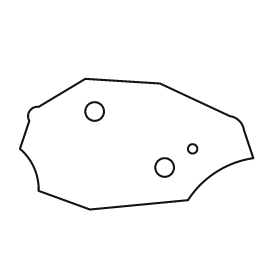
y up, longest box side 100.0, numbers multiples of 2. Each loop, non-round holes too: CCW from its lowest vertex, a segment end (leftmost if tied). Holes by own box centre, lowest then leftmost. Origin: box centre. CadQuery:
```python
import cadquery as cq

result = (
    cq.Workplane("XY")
    .moveTo(-20.0, -28.0)
    .lineTo(22.0, -24.0)
    .threePointArc((34.0, -12.0), (50.0, -6.0))
    .lineTo(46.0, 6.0)
    .threePointArc((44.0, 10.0), (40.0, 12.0))
    .lineTo(10.0, 26.0)
    .lineTo(-22.0, 28.0)
    .lineTo(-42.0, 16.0)
    .threePointArc((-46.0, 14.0), (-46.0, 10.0))
    .lineTo(-50.0, -2.0)
    .threePointArc((-44.0, -10.0), (-42.0, -20.0))
    .close()
    .moveTo(12.0, -10.0)
    .circle(4.0)
    .moveTo(24.0, -2.0)
    .circle(2.0)
    .moveTo(-18.0, 14.0)
    .circle(4.0)
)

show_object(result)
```